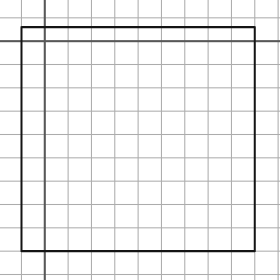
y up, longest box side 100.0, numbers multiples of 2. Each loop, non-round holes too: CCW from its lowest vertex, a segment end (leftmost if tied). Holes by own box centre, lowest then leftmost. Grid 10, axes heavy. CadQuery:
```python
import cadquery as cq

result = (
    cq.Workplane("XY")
    .moveTo(-10.0, -90.0)
    .lineTo(90.0, -90.0)
    .lineTo(90.0, 6.0)
    .lineTo(-10.0, 6.0)
    .close()
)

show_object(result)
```